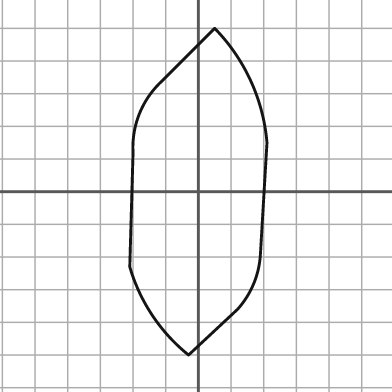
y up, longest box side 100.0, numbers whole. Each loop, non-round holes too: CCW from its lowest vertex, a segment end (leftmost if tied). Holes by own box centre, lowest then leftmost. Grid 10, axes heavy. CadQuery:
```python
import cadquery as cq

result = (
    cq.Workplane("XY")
    .moveTo(-3.0, -50.0)
    .lineTo(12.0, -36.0)
    .threePointArc((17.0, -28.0), (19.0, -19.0))
    .lineTo(21.0, 15.0)
    .threePointArc((16.0, 34.0), (5.0, 50.0))
    .lineTo(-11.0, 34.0)
    .threePointArc((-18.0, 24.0), (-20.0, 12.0))
    .lineTo(-21.0, -23.0)
    .threePointArc((-14.0, -38.0), (-3.0, -50.0))
    .close()
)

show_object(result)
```